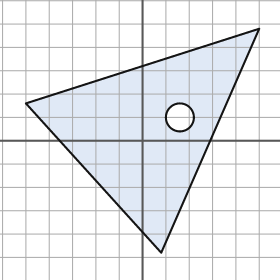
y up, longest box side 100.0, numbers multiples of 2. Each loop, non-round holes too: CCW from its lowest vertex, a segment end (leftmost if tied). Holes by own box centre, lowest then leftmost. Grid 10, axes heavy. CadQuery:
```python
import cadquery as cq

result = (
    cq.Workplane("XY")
    .moveTo(8.0, -48.0)
    .lineTo(50.0, 48.0)
    .lineTo(-50.0, 16.0)
    .close()
    .moveTo(16.0, 10.0)
    .circle(6.0)
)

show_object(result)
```